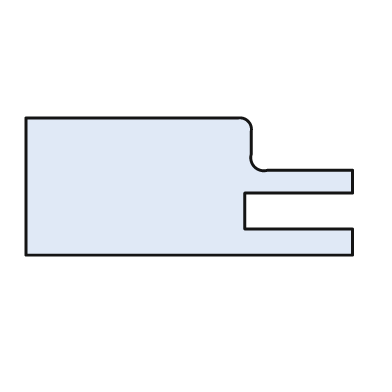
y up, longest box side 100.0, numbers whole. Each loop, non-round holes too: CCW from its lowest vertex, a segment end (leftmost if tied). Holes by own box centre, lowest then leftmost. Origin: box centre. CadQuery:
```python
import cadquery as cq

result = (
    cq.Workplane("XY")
    .moveTo(-50.0, -21.0)
    .lineTo(50.0, -21.0)
    .lineTo(50.0, -13.0)
    .lineTo(17.0, -13.0)
    .lineTo(17.0, -2.0)
    .lineTo(50.0, -2.0)
    .lineTo(50.0, 5.0)
    .lineTo(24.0, 5.0)
    .threePointArc((20.0, 6.0), (19.0, 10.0))
    .lineTo(19.0, 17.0)
    .threePointArc((18.0, 20.0), (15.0, 21.0))
    .lineTo(-50.0, 21.0)
    .close()
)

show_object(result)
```